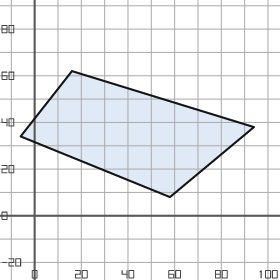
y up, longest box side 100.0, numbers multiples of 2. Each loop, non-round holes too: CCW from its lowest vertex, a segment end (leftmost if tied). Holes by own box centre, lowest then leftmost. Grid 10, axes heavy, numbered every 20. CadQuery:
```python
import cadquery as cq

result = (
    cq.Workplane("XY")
    .moveTo(58.0, 8.0)
    .lineTo(94.0, 38.0)
    .lineTo(16.0, 62.0)
    .lineTo(-6.0, 34.0)
    .close()
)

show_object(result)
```